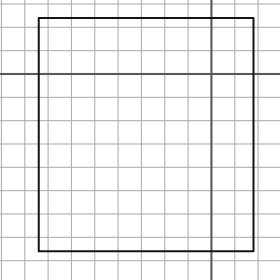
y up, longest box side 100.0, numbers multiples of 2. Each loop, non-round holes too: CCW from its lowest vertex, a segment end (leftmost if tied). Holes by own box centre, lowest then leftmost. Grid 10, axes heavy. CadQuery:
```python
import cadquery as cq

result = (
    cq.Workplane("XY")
    .moveTo(-74.0, -76.0)
    .lineTo(18.0, -76.0)
    .lineTo(18.0, 24.0)
    .lineTo(-74.0, 24.0)
    .close()
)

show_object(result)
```